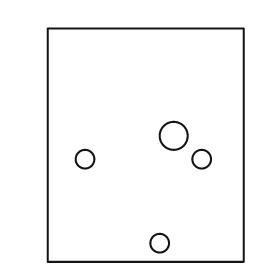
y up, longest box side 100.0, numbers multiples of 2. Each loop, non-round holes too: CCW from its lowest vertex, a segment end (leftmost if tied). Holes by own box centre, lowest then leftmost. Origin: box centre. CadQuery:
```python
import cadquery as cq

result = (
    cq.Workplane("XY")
    .moveTo(-42.0, -50.0)
    .lineTo(42.0, -50.0)
    .lineTo(42.0, 50.0)
    .lineTo(-42.0, 50.0)
    .close()
    .moveTo(6.0, -42.0)
    .circle(4.0)
    .moveTo(-26.0, -6.0)
    .circle(4.0)
    .moveTo(24.0, -6.0)
    .circle(4.0)
    .moveTo(12.0, 4.0)
    .circle(6.0)
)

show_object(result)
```